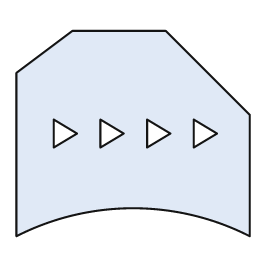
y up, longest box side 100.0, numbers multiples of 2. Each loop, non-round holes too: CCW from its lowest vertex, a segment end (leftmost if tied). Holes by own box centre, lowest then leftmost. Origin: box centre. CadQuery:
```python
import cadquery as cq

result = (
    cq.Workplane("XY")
    .moveTo(-50.0, -44.0)
    .threePointArc((0.0, -32.0), (50.0, -44.0))
    .lineTo(50.0, 8.0)
    .lineTo(14.0, 44.0)
    .lineTo(-26.0, 44.0)
    .lineTo(-50.0, 26.0)
    .close()
    .moveTo(-34.0, -6.0)
    .lineTo(-24.0, 0.0)
    .lineTo(-34.0, 6.0)
    .close()
    .moveTo(-14.0, -6.0)
    .lineTo(-4.0, 0.0)
    .lineTo(-14.0, 6.0)
    .close()
    .moveTo(6.0, -6.0)
    .lineTo(16.0, 0.0)
    .lineTo(6.0, 6.0)
    .close()
    .moveTo(26.0, -6.0)
    .lineTo(36.0, 0.0)
    .lineTo(26.0, 6.0)
    .close()
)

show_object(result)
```